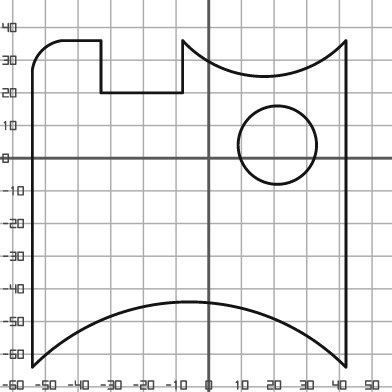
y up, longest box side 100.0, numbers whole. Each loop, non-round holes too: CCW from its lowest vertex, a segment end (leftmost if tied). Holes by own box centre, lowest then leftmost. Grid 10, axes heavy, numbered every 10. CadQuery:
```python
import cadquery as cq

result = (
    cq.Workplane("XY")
    .moveTo(-54.0, -64.0)
    .threePointArc((-6.0, -44.0), (42.0, -64.0))
    .lineTo(42.0, 36.0)
    .threePointArc((17.0, 25.0), (-8.0, 36.0))
    .lineTo(-8.0, 20.0)
    .lineTo(-33.0, 20.0)
    .lineTo(-33.0, 36.0)
    .lineTo(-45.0, 36.0)
    .threePointArc((-51.0, 33.0), (-54.0, 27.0))
    .close()
    .moveTo(21.0, 4.0)
    .circle(12.0)
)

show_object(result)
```